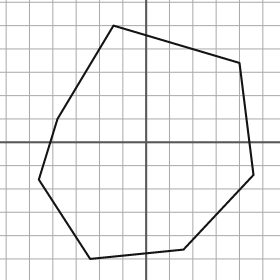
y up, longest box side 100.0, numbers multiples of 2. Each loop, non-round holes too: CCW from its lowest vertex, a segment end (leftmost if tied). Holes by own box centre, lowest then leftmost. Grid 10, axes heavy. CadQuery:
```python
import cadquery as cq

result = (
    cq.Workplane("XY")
    .moveTo(-24.0, -50.0)
    .lineTo(16.0, -46.0)
    .lineTo(46.0, -14.0)
    .lineTo(40.0, 34.0)
    .lineTo(-14.0, 50.0)
    .lineTo(-38.0, 10.0)
    .lineTo(-46.0, -16.0)
    .close()
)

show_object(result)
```